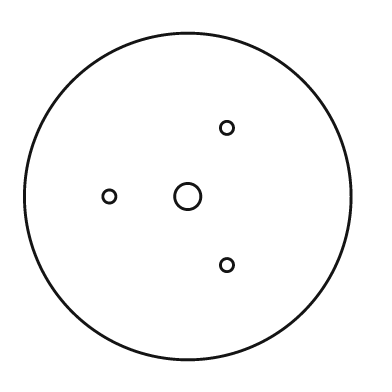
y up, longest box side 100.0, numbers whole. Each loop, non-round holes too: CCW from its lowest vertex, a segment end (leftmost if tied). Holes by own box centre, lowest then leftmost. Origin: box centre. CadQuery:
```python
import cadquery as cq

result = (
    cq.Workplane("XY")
    .moveTo(0.0, 0.0)
    .circle(50.0)
    .moveTo(12.0, -21.0)
    .circle(2.0)
    .moveTo(-24.0, 0.0)
    .circle(2.0)
    .moveTo(0.0, 0.0)
    .circle(4.0)
    .moveTo(12.0, 21.0)
    .circle(2.0)
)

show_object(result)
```